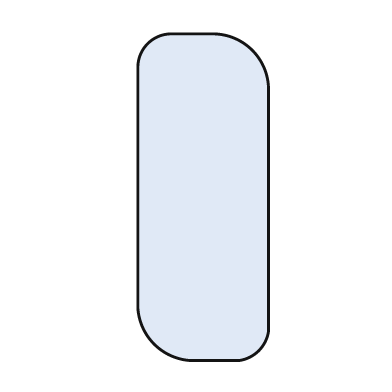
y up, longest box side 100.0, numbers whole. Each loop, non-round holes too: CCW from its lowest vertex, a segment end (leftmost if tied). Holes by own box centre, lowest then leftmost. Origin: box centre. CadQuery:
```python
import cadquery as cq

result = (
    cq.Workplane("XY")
    .moveTo(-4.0, -50.0)
    .lineTo(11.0, -50.0)
    .threePointArc((17.0, -47.0), (20.0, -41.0))
    .lineTo(20.0, 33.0)
    .threePointArc((15.0, 45.0), (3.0, 50.0))
    .lineTo(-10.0, 50.0)
    .threePointArc((-17.0, 47.0), (-20.0, 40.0))
    .lineTo(-20.0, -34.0)
    .threePointArc((-15.0, -45.0), (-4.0, -50.0))
    .close()
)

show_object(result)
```